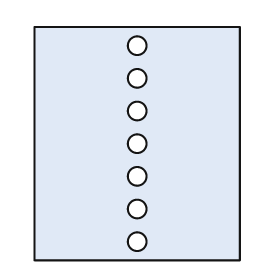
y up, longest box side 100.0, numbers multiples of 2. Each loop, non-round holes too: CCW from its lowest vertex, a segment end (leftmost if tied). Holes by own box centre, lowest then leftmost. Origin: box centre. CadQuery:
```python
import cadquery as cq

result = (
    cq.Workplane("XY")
    .moveTo(-44.0, -50.0)
    .lineTo(44.0, -50.0)
    .lineTo(44.0, 50.0)
    .lineTo(-44.0, 50.0)
    .close()
    .moveTo(0.0, -42.0)
    .circle(4.0)
    .moveTo(0.0, -28.0)
    .circle(4.0)
    .moveTo(0.0, -14.0)
    .circle(4.0)
    .moveTo(0.0, 0.0)
    .circle(4.0)
    .moveTo(0.0, 14.0)
    .circle(4.0)
    .moveTo(0.0, 28.0)
    .circle(4.0)
    .moveTo(0.0, 42.0)
    .circle(4.0)
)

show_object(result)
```